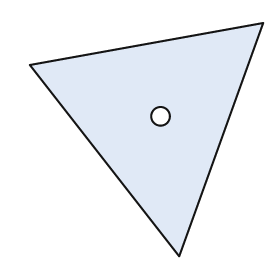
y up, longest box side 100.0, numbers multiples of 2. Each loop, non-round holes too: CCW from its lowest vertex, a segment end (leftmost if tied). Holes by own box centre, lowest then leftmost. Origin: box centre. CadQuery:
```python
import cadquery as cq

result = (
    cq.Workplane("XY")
    .moveTo(14.0, -50.0)
    .lineTo(50.0, 50.0)
    .lineTo(-50.0, 32.0)
    .close()
    .moveTo(6.0, 10.0)
    .circle(4.0)
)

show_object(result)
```